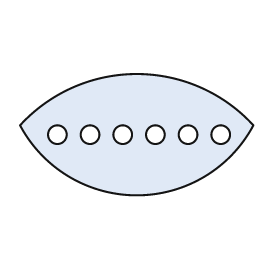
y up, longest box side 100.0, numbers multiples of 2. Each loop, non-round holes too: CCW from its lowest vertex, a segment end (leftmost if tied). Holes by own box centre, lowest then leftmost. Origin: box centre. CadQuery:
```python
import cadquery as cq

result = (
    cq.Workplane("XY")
    .moveTo(-50.0, 4.0)
    .threePointArc((0.0, -26.0), (50.0, 4.0))
    .threePointArc((0.0, 26.0), (-50.0, 4.0))
    .close()
    .moveTo(-34.0, 0.0)
    .circle(4.0)
    .moveTo(-20.0, 0.0)
    .circle(4.0)
    .moveTo(-6.0, 0.0)
    .circle(4.0)
    .moveTo(8.0, 0.0)
    .circle(4.0)
    .moveTo(22.0, 0.0)
    .circle(4.0)
    .moveTo(36.0, 0.0)
    .circle(4.0)
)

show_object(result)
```